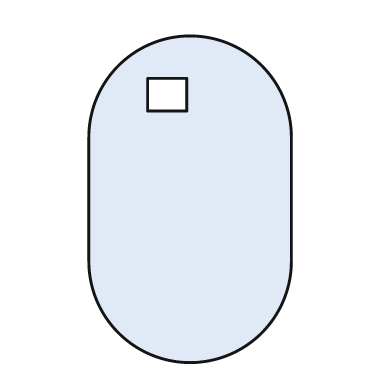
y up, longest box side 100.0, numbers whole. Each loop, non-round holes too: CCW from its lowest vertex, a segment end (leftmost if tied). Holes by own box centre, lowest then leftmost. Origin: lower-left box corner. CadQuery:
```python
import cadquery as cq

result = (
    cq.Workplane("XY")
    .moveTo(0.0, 31.0)
    .threePointArc((31.0, 0.0), (62.0, 31.0))
    .lineTo(62.0, 69.0)
    .threePointArc((31.0, 100.0), (0.0, 69.0))
    .close()
    .moveTo(18.0, 77.0)
    .lineTo(30.0, 77.0)
    .lineTo(30.0, 87.0)
    .lineTo(18.0, 87.0)
    .close()
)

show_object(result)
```